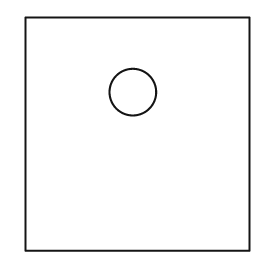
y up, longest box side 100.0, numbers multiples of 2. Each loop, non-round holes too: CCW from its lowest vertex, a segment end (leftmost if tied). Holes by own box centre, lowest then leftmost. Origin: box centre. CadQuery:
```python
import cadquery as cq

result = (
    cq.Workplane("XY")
    .moveTo(-48.0, -50.0)
    .lineTo(48.0, -50.0)
    .lineTo(48.0, 50.0)
    .lineTo(-48.0, 50.0)
    .close()
    .moveTo(-2.0, 18.0)
    .circle(10.0)
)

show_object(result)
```